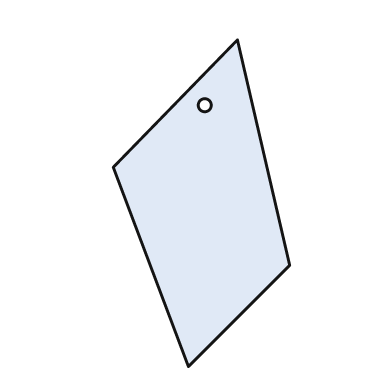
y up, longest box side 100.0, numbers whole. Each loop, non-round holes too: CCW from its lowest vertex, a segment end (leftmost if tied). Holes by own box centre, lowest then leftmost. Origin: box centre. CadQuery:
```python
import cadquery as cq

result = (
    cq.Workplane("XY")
    .moveTo(-4.0, -50.0)
    .lineTo(27.0, -19.0)
    .lineTo(11.0, 50.0)
    .lineTo(-27.0, 11.0)
    .close()
    .moveTo(1.0, 30.0)
    .circle(2.0)
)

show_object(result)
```